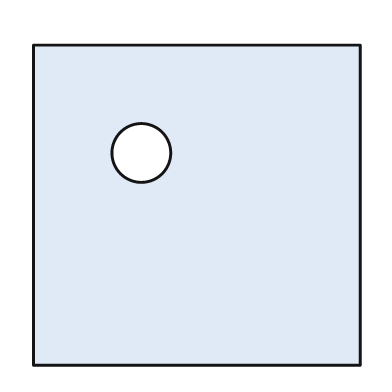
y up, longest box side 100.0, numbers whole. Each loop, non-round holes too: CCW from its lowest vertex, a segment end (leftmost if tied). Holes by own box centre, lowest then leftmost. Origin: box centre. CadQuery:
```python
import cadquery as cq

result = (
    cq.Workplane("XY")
    .moveTo(-50.0, -49.0)
    .lineTo(50.0, -49.0)
    .lineTo(50.0, 49.0)
    .lineTo(-50.0, 49.0)
    .close()
    .moveTo(-17.0, 16.0)
    .circle(9.0)
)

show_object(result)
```